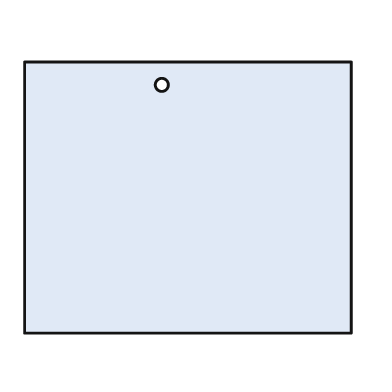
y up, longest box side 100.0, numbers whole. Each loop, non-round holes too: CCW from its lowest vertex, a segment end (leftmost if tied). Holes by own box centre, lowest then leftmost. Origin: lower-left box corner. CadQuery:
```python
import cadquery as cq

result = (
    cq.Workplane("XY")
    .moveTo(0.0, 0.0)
    .lineTo(100.0, 0.0)
    .lineTo(100.0, 83.0)
    .lineTo(0.0, 83.0)
    .close()
    .moveTo(42.0, 76.0)
    .circle(2.0)
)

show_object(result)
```